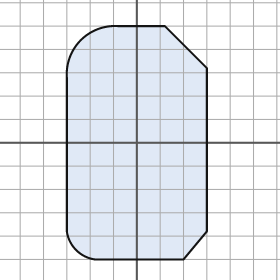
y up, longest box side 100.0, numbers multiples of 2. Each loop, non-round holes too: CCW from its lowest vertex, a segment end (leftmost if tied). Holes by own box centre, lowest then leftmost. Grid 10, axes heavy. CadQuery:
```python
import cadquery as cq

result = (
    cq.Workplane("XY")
    .moveTo(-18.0, -50.0)
    .lineTo(20.0, -50.0)
    .lineTo(30.0, -38.0)
    .lineTo(30.0, 32.0)
    .lineTo(12.0, 50.0)
    .lineTo(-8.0, 50.0)
    .threePointArc((-24.0, 44.0), (-30.0, 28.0))
    .lineTo(-30.0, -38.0)
    .threePointArc((-26.0, -46.0), (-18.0, -50.0))
    .close()
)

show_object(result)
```